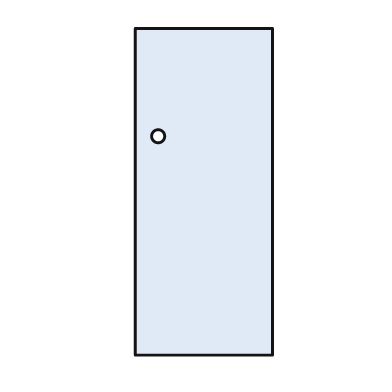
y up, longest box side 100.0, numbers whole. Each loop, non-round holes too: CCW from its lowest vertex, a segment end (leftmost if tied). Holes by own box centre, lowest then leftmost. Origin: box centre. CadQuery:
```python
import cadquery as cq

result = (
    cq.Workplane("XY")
    .moveTo(-21.0, -50.0)
    .lineTo(21.0, -50.0)
    .lineTo(21.0, 50.0)
    .lineTo(-21.0, 50.0)
    .close()
    .moveTo(-14.0, 17.0)
    .circle(2.0)
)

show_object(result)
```